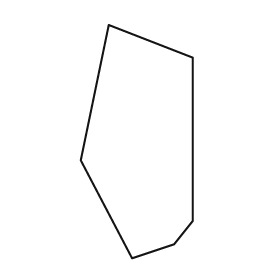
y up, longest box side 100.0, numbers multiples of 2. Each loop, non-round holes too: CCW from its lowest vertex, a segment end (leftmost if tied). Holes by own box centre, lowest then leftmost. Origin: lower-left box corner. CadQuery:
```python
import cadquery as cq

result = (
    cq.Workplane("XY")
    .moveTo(22.0, 0.0)
    .lineTo(40.0, 6.0)
    .lineTo(48.0, 16.0)
    .lineTo(48.0, 86.0)
    .lineTo(12.0, 100.0)
    .lineTo(0.0, 42.0)
    .close()
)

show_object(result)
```